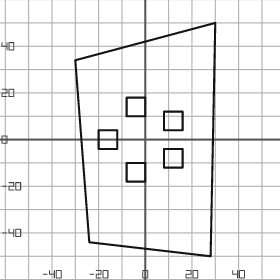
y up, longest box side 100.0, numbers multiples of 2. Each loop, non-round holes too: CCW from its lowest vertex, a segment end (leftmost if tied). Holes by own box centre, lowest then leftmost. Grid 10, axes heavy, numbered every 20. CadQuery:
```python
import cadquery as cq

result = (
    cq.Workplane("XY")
    .moveTo(28.0, -50.0)
    .lineTo(30.0, 50.0)
    .lineTo(-30.0, 34.0)
    .lineTo(-24.0, -44.0)
    .close()
    .moveTo(-8.0, -18.0)
    .lineTo(0.0, -18.0)
    .lineTo(0.0, -10.0)
    .lineTo(-8.0, -10.0)
    .close()
    .moveTo(8.0, -12.0)
    .lineTo(16.0, -12.0)
    .lineTo(16.0, -4.0)
    .lineTo(8.0, -4.0)
    .close()
    .moveTo(-20.0, -4.0)
    .lineTo(-12.0, -4.0)
    .lineTo(-12.0, 4.0)
    .lineTo(-20.0, 4.0)
    .close()
    .moveTo(8.0, 4.0)
    .lineTo(16.0, 4.0)
    .lineTo(16.0, 12.0)
    .lineTo(8.0, 12.0)
    .close()
    .moveTo(-8.0, 10.0)
    .lineTo(0.0, 10.0)
    .lineTo(0.0, 18.0)
    .lineTo(-8.0, 18.0)
    .close()
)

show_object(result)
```